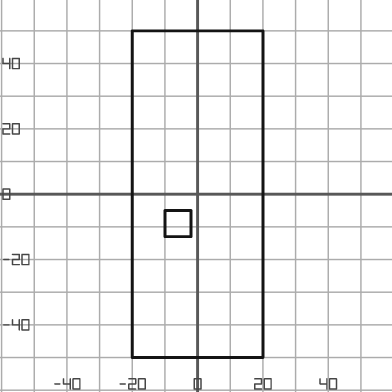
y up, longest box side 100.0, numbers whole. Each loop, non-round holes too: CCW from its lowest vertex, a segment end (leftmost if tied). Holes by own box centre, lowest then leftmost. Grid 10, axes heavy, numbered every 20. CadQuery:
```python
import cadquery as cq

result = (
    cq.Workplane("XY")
    .moveTo(-20.0, -50.0)
    .lineTo(20.0, -50.0)
    .lineTo(20.0, 50.0)
    .lineTo(-20.0, 50.0)
    .close()
    .moveTo(-10.0, -13.0)
    .lineTo(-2.0, -13.0)
    .lineTo(-2.0, -5.0)
    .lineTo(-10.0, -5.0)
    .close()
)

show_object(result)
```